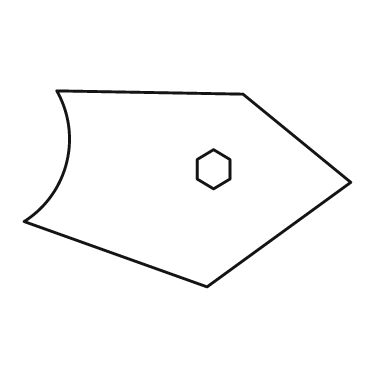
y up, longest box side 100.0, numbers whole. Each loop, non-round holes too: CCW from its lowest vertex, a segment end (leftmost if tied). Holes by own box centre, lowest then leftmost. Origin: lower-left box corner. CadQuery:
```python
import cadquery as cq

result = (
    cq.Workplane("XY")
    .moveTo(56.0, 0.0)
    .lineTo(100.0, 32.0)
    .lineTo(67.0, 59.0)
    .lineTo(10.0, 60.0)
    .threePointArc((13.0, 38.0), (0.0, 20.0))
    .close()
    .moveTo(58.0, 30.0)
    .lineTo(63.0, 33.0)
    .lineTo(63.0, 39.0)
    .lineTo(58.0, 42.0)
    .lineTo(53.0, 39.0)
    .lineTo(53.0, 33.0)
    .close()
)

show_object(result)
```